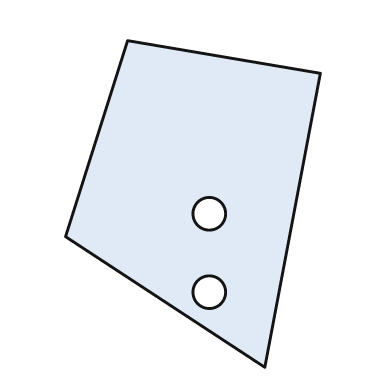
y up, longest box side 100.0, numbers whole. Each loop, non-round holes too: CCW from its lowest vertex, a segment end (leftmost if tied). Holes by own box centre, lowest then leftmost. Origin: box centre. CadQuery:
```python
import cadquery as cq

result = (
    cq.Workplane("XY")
    .moveTo(22.0, -50.0)
    .lineTo(39.0, 40.0)
    .lineTo(-20.0, 50.0)
    .lineTo(-39.0, -10.0)
    .close()
    .moveTo(5.0, -27.0)
    .circle(5.0)
    .moveTo(5.0, -3.0)
    .circle(5.0)
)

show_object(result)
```